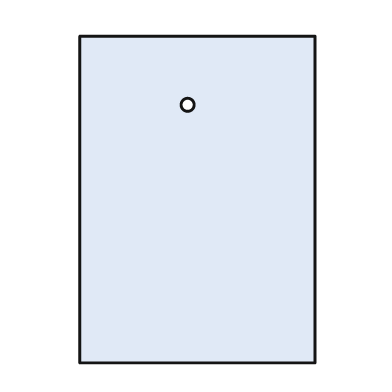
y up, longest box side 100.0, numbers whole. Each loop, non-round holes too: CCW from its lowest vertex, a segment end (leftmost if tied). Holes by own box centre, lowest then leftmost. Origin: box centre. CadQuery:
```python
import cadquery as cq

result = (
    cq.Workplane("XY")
    .moveTo(-36.0, -50.0)
    .lineTo(36.0, -50.0)
    .lineTo(36.0, 50.0)
    .lineTo(-36.0, 50.0)
    .close()
    .moveTo(-3.0, 29.0)
    .circle(2.0)
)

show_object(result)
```